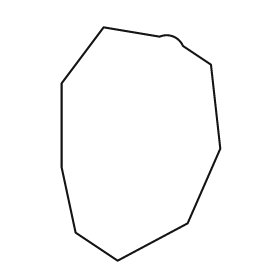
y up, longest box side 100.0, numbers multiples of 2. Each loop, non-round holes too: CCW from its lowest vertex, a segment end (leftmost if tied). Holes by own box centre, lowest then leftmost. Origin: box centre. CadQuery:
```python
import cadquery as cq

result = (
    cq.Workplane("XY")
    .moveTo(-10.0, -50.0)
    .lineTo(20.0, -34.0)
    .lineTo(34.0, -2.0)
    .lineTo(30.0, 34.0)
    .lineTo(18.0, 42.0)
    .threePointArc((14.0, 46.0), (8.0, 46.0))
    .lineTo(-16.0, 50.0)
    .lineTo(-34.0, 26.0)
    .lineTo(-34.0, -10.0)
    .lineTo(-28.0, -38.0)
    .close()
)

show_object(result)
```